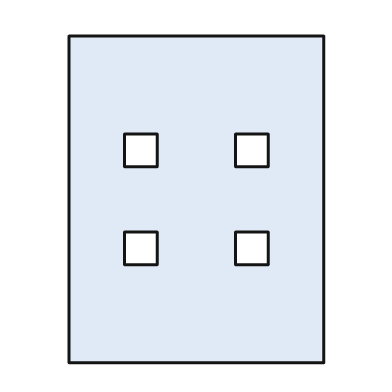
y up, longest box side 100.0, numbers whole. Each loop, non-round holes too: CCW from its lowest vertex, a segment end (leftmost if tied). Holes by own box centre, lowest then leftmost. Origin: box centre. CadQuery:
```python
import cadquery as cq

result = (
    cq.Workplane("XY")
    .moveTo(-39.0, -50.0)
    .lineTo(39.0, -50.0)
    .lineTo(39.0, 50.0)
    .lineTo(-39.0, 50.0)
    .close()
    .moveTo(-22.0, -20.0)
    .lineTo(-12.0, -20.0)
    .lineTo(-12.0, -10.0)
    .lineTo(-22.0, -10.0)
    .close()
    .moveTo(12.0, -20.0)
    .lineTo(22.0, -20.0)
    .lineTo(22.0, -10.0)
    .lineTo(12.0, -10.0)
    .close()
    .moveTo(-22.0, 10.0)
    .lineTo(-12.0, 10.0)
    .lineTo(-12.0, 20.0)
    .lineTo(-22.0, 20.0)
    .close()
    .moveTo(12.0, 10.0)
    .lineTo(22.0, 10.0)
    .lineTo(22.0, 20.0)
    .lineTo(12.0, 20.0)
    .close()
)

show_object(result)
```